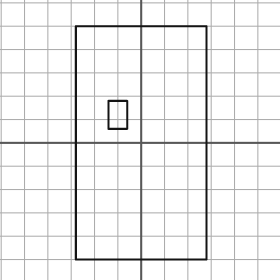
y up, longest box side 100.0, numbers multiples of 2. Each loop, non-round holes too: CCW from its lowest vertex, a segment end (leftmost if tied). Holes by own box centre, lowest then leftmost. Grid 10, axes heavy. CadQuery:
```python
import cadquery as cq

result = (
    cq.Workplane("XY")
    .moveTo(-28.0, -50.0)
    .lineTo(28.0, -50.0)
    .lineTo(28.0, 50.0)
    .lineTo(-28.0, 50.0)
    .close()
    .moveTo(-14.0, 6.0)
    .lineTo(-6.0, 6.0)
    .lineTo(-6.0, 18.0)
    .lineTo(-14.0, 18.0)
    .close()
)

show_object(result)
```